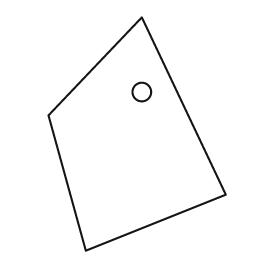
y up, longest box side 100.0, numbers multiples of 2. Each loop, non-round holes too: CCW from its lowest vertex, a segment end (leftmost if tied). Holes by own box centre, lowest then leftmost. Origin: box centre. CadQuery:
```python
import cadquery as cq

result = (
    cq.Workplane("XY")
    .moveTo(-22.0, -50.0)
    .lineTo(38.0, -26.0)
    .lineTo(2.0, 50.0)
    .lineTo(-38.0, 8.0)
    .close()
    .moveTo(2.0, 18.0)
    .circle(4.0)
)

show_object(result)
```